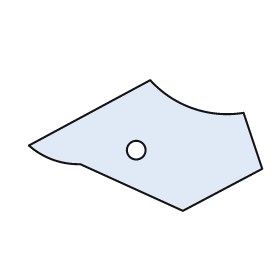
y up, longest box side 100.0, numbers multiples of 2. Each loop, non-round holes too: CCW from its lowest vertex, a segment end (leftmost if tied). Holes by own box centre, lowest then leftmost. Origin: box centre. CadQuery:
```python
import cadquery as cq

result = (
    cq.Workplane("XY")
    .moveTo(16.0, -28.0)
    .lineTo(50.0, -10.0)
    .lineTo(42.0, 14.0)
    .threePointArc((20.0, 16.0), (2.0, 28.0))
    .lineTo(-50.0, 0.0)
    .threePointArc((-40.0, -6.0), (-28.0, -8.0))
    .close()
    .moveTo(-4.0, -2.0)
    .circle(4.0)
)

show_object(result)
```